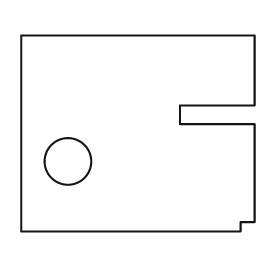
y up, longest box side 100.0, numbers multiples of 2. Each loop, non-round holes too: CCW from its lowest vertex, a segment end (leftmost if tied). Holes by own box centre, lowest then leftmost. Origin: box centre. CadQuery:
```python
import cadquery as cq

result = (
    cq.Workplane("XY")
    .moveTo(-50.0, -42.0)
    .lineTo(44.0, -42.0)
    .lineTo(44.0, -38.0)
    .lineTo(50.0, -38.0)
    .lineTo(50.0, 4.0)
    .lineTo(18.0, 4.0)
    .lineTo(18.0, 12.0)
    .lineTo(50.0, 12.0)
    .lineTo(50.0, 42.0)
    .lineTo(-50.0, 42.0)
    .close()
    .moveTo(-30.0, -12.0)
    .circle(10.0)
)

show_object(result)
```